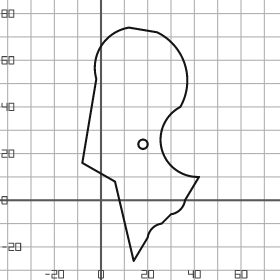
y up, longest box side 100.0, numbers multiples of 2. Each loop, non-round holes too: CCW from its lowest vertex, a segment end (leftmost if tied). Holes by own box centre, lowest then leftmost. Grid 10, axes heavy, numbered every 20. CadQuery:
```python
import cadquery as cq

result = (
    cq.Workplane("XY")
    .moveTo(14.0, -26.0)
    .lineTo(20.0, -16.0)
    .threePointArc((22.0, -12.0), (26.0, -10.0))
    .lineTo(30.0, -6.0)
    .threePointArc((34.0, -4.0), (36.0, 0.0))
    .lineTo(42.0, 10.0)
    .threePointArc((26.0, 22.0), (34.0, 40.0))
    .threePointArc((36.0, 58.0), (24.0, 72.0))
    .lineTo(12.0, 74.0)
    .threePointArc((0.0, 66.0), (-2.0, 52.0))
    .lineTo(-8.0, 16.0)
    .lineTo(6.0, 8.0)
    .close()
    .moveTo(18.0, 24.0)
    .circle(2.0)
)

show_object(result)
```